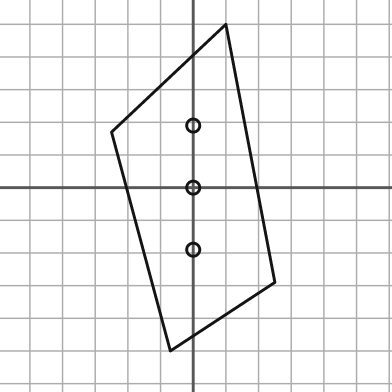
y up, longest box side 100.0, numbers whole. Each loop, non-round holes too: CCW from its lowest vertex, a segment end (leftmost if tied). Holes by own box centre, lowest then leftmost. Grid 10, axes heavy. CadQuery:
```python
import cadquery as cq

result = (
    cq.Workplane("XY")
    .moveTo(-7.0, -50.0)
    .lineTo(25.0, -29.0)
    .lineTo(10.0, 50.0)
    .lineTo(-25.0, 17.0)
    .close()
    .moveTo(0.0, -19.0)
    .circle(2.0)
    .moveTo(0.0, 0.0)
    .circle(2.0)
    .moveTo(0.0, 19.0)
    .circle(2.0)
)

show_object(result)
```